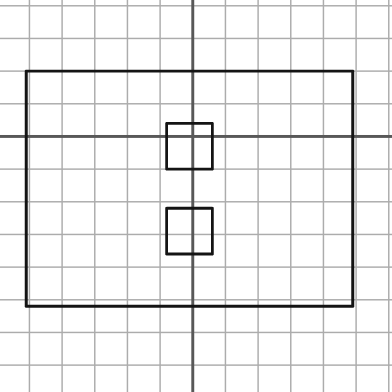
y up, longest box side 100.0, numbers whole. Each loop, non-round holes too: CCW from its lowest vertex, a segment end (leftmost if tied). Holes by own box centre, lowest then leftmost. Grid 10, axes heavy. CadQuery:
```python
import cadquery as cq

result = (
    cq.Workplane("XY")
    .moveTo(-51.0, -52.0)
    .lineTo(49.0, -52.0)
    .lineTo(49.0, 20.0)
    .lineTo(-51.0, 20.0)
    .close()
    .moveTo(-8.0, -36.0)
    .lineTo(6.0, -36.0)
    .lineTo(6.0, -22.0)
    .lineTo(-8.0, -22.0)
    .close()
    .moveTo(-8.0, -10.0)
    .lineTo(6.0, -10.0)
    .lineTo(6.0, 4.0)
    .lineTo(-8.0, 4.0)
    .close()
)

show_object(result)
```